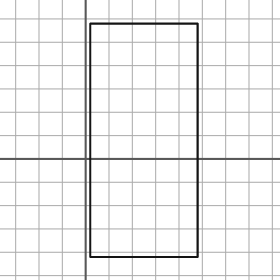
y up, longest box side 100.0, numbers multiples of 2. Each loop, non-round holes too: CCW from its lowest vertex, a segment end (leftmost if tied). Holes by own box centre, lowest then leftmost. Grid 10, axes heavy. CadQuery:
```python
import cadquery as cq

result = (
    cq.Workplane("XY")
    .moveTo(2.0, -42.0)
    .lineTo(48.0, -42.0)
    .lineTo(48.0, 58.0)
    .lineTo(2.0, 58.0)
    .close()
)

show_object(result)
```